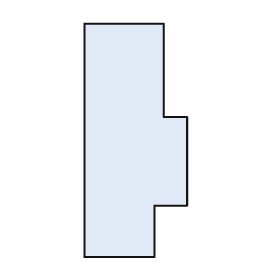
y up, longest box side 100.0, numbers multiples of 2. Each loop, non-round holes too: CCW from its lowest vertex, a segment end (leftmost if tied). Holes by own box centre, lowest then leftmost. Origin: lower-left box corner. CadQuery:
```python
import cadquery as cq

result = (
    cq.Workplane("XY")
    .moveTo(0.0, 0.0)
    .lineTo(30.0, 0.0)
    .lineTo(30.0, 22.0)
    .lineTo(44.0, 22.0)
    .lineTo(44.0, 60.0)
    .lineTo(34.0, 60.0)
    .lineTo(34.0, 100.0)
    .lineTo(0.0, 100.0)
    .close()
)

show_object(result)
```